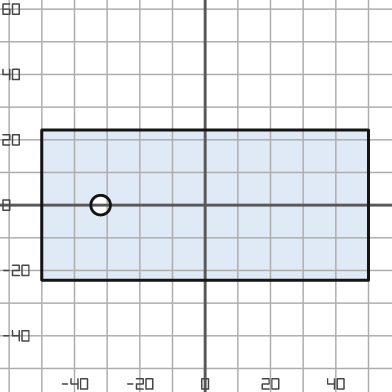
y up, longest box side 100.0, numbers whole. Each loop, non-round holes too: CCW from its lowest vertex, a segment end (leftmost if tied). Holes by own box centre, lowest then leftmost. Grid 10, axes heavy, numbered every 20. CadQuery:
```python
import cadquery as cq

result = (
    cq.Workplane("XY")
    .moveTo(-50.0, -23.0)
    .lineTo(50.0, -23.0)
    .lineTo(50.0, 23.0)
    .lineTo(-50.0, 23.0)
    .close()
    .moveTo(-32.0, 0.0)
    .circle(3.0)
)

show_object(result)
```